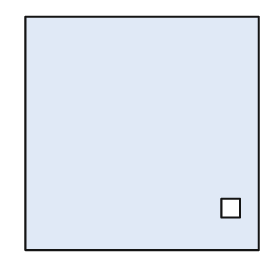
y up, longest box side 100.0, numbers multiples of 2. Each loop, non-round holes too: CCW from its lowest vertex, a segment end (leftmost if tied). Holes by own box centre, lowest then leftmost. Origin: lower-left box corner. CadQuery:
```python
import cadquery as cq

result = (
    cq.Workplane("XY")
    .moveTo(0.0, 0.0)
    .lineTo(100.0, 0.0)
    .lineTo(100.0, 100.0)
    .lineTo(0.0, 100.0)
    .close()
    .moveTo(84.0, 14.0)
    .lineTo(92.0, 14.0)
    .lineTo(92.0, 22.0)
    .lineTo(84.0, 22.0)
    .close()
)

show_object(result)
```